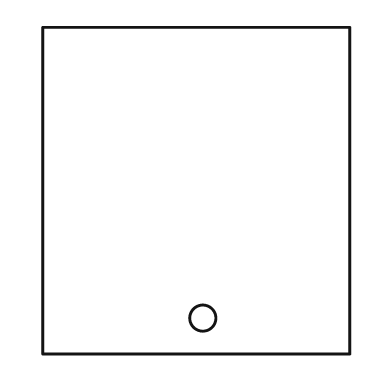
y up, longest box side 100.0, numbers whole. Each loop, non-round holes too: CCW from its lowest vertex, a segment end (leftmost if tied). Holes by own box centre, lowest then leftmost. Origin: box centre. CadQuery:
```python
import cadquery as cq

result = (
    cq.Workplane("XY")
    .moveTo(-47.0, -50.0)
    .lineTo(47.0, -50.0)
    .lineTo(47.0, 50.0)
    .lineTo(-47.0, 50.0)
    .close()
    .moveTo(2.0, -39.0)
    .circle(4.0)
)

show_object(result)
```